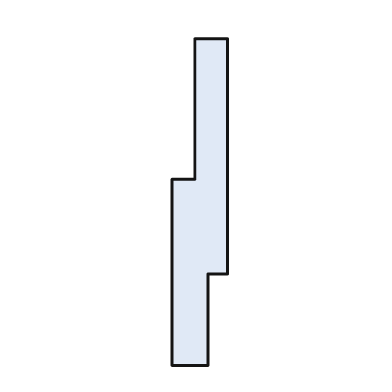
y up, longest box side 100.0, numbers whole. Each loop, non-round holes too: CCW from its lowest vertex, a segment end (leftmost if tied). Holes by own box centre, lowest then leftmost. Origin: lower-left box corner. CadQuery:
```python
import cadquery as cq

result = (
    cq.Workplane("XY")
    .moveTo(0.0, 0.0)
    .lineTo(11.0, 0.0)
    .lineTo(11.0, 28.0)
    .lineTo(17.0, 28.0)
    .lineTo(17.0, 100.0)
    .lineTo(7.0, 100.0)
    .lineTo(7.0, 57.0)
    .lineTo(0.0, 57.0)
    .close()
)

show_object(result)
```